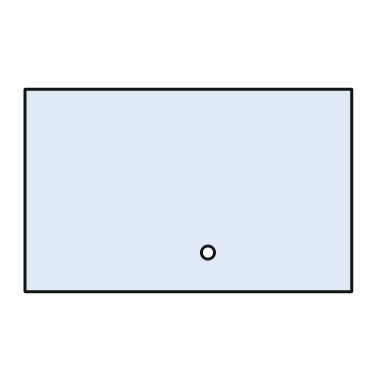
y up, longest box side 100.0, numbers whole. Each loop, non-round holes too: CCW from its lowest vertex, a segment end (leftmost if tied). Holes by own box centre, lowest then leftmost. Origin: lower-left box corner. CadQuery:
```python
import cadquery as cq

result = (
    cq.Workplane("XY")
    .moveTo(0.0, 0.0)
    .lineTo(100.0, 0.0)
    .lineTo(100.0, 62.0)
    .lineTo(0.0, 62.0)
    .close()
    .moveTo(56.0, 12.0)
    .circle(2.0)
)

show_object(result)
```